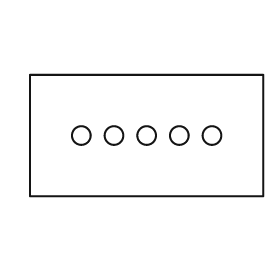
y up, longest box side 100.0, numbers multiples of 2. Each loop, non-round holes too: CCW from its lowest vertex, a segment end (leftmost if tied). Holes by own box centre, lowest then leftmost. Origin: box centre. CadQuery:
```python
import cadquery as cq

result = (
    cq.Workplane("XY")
    .moveTo(-50.0, -26.0)
    .lineTo(50.0, -26.0)
    .lineTo(50.0, 26.0)
    .lineTo(-50.0, 26.0)
    .close()
    .moveTo(-28.0, 0.0)
    .circle(4.0)
    .moveTo(-14.0, 0.0)
    .circle(4.0)
    .moveTo(0.0, 0.0)
    .circle(4.0)
    .moveTo(14.0, 0.0)
    .circle(4.0)
    .moveTo(28.0, 0.0)
    .circle(4.0)
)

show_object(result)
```